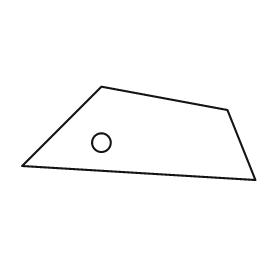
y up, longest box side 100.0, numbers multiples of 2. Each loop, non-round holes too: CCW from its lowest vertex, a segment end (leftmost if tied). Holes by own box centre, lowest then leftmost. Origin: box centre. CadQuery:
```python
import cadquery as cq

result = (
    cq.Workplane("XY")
    .moveTo(50.0, -20.0)
    .lineTo(38.0, 10.0)
    .lineTo(-16.0, 20.0)
    .lineTo(-50.0, -14.0)
    .close()
    .moveTo(-16.0, -4.0)
    .circle(4.0)
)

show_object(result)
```